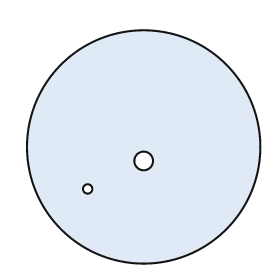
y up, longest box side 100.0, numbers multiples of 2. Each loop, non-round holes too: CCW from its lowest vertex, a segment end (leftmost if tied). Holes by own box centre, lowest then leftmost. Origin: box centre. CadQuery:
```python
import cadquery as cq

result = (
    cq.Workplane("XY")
    .moveTo(0.0, 0.0)
    .circle(50.0)
    .moveTo(-24.0, -18.0)
    .circle(2.0)
    .moveTo(0.0, -6.0)
    .circle(4.0)
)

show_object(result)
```